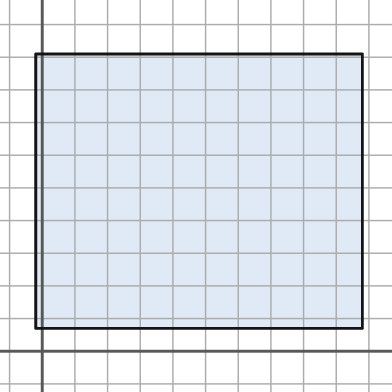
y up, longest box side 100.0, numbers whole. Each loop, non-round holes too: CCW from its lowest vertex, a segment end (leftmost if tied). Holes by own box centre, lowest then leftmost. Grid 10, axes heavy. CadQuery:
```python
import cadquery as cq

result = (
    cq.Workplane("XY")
    .moveTo(-2.0, 7.0)
    .lineTo(98.0, 7.0)
    .lineTo(98.0, 91.0)
    .lineTo(-2.0, 91.0)
    .close()
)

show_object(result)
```